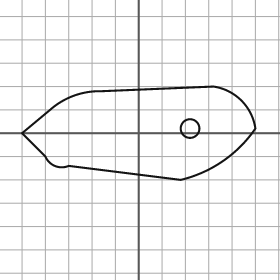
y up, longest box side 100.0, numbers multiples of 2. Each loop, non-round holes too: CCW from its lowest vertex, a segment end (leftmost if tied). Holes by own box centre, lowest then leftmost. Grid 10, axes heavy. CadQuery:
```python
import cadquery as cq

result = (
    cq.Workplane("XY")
    .moveTo(18.0, -20.0)
    .threePointArc((36.0, -12.0), (50.0, 2.0))
    .threePointArc((44.0, 14.0), (32.0, 20.0))
    .lineTo(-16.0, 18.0)
    .threePointArc((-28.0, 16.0), (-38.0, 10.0))
    .lineTo(-50.0, 0.0)
    .lineTo(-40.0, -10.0)
    .threePointArc((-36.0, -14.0), (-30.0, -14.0))
    .close()
    .moveTo(22.0, 2.0)
    .circle(4.0)
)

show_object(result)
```